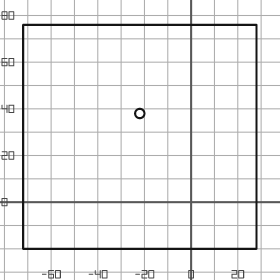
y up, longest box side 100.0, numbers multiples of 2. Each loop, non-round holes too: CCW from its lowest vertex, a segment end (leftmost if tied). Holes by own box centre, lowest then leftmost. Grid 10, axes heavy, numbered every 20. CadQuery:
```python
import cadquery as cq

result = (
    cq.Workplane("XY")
    .moveTo(-72.0, -20.0)
    .lineTo(28.0, -20.0)
    .lineTo(28.0, 76.0)
    .lineTo(-72.0, 76.0)
    .close()
    .moveTo(-22.0, 38.0)
    .circle(2.0)
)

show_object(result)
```